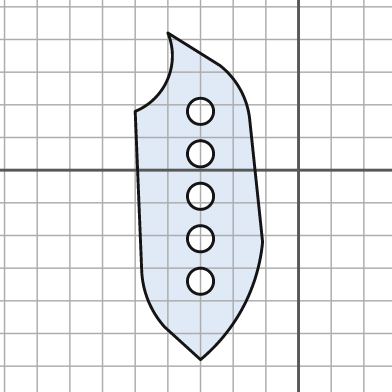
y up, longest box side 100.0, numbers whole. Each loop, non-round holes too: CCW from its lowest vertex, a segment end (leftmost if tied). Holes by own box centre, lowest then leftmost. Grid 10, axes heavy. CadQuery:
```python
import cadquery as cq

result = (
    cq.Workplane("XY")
    .moveTo(-30.0, -58.0)
    .threePointArc((-17.0, -42.0), (-11.0, -22.0))
    .lineTo(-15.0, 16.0)
    .threePointArc((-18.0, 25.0), (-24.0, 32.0))
    .lineTo(-40.0, 42.0)
    .threePointArc((-40.0, 28.0), (-50.0, 18.0))
    .lineTo(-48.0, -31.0)
    .threePointArc((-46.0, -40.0), (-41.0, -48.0))
    .close()
    .moveTo(-30.0, -34.0)
    .circle(4.0)
    .moveTo(-30.0, -21.0)
    .circle(4.0)
    .moveTo(-30.0, -8.0)
    .circle(4.0)
    .moveTo(-30.0, 5.0)
    .circle(4.0)
    .moveTo(-30.0, 18.0)
    .circle(4.0)
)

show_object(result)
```